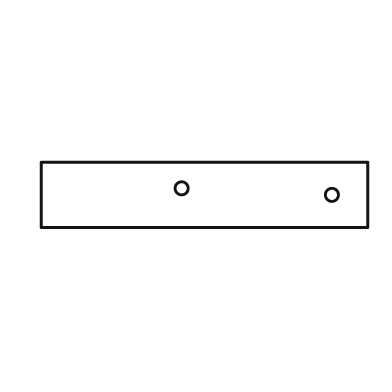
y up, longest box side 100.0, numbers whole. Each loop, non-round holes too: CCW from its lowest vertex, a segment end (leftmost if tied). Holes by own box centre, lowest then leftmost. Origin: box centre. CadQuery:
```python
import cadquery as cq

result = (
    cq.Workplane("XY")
    .moveTo(-50.0, -10.0)
    .lineTo(50.0, -10.0)
    .lineTo(50.0, 10.0)
    .lineTo(-50.0, 10.0)
    .close()
    .moveTo(39.0, 0.0)
    .circle(2.0)
    .moveTo(-7.0, 2.0)
    .circle(2.0)
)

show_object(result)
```